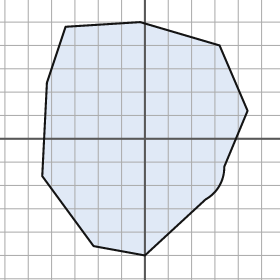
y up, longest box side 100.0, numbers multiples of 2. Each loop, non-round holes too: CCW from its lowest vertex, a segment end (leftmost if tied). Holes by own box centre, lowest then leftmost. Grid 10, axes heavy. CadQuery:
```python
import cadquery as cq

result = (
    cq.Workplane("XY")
    .moveTo(0.0, -50.0)
    .lineTo(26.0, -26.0)
    .threePointArc((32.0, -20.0), (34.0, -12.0))
    .lineTo(44.0, 12.0)
    .lineTo(32.0, 40.0)
    .lineTo(-2.0, 50.0)
    .lineTo(-34.0, 48.0)
    .lineTo(-42.0, 24.0)
    .lineTo(-44.0, -16.0)
    .lineTo(-22.0, -46.0)
    .close()
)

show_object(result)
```